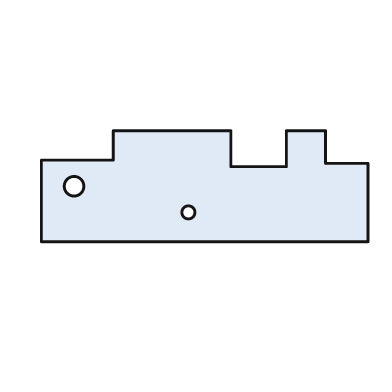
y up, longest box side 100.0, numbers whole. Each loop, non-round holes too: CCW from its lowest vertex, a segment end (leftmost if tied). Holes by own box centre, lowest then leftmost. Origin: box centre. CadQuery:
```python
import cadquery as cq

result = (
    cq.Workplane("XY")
    .moveTo(-50.0, -17.0)
    .lineTo(50.0, -17.0)
    .lineTo(50.0, 7.0)
    .lineTo(37.0, 7.0)
    .lineTo(37.0, 17.0)
    .lineTo(25.0, 17.0)
    .lineTo(25.0, 6.0)
    .lineTo(8.0, 6.0)
    .lineTo(8.0, 17.0)
    .lineTo(-28.0, 17.0)
    .lineTo(-28.0, 8.0)
    .lineTo(-50.0, 8.0)
    .close()
    .moveTo(-5.0, -8.0)
    .circle(2.0)
    .moveTo(-40.0, 0.0)
    .circle(3.0)
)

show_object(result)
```